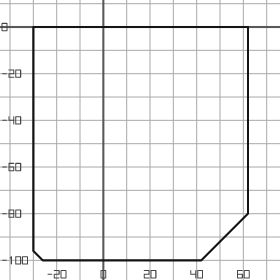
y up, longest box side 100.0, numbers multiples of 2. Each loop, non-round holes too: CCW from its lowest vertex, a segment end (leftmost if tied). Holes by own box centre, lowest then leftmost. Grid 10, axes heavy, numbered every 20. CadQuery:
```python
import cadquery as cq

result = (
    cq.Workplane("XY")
    .moveTo(-26.0, -100.0)
    .lineTo(42.0, -100.0)
    .lineTo(62.0, -80.0)
    .lineTo(62.0, 0.0)
    .lineTo(-30.0, 0.0)
    .lineTo(-30.0, -96.0)
    .close()
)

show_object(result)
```